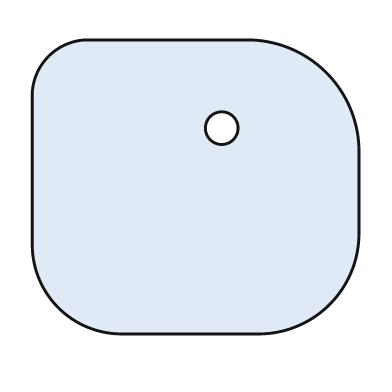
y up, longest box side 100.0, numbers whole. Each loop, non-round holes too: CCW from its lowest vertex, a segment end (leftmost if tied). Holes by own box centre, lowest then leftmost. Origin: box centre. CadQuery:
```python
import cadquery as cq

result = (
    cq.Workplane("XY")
    .moveTo(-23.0, -45.0)
    .lineTo(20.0, -45.0)
    .threePointArc((41.0, -36.0), (50.0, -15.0))
    .lineTo(50.0, 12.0)
    .threePointArc((40.0, 35.0), (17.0, 45.0))
    .lineTo(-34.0, 45.0)
    .threePointArc((-45.0, 40.0), (-50.0, 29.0))
    .lineTo(-50.0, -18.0)
    .threePointArc((-42.0, -37.0), (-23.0, -45.0))
    .close()
    .moveTo(8.0, 18.0)
    .circle(5.0)
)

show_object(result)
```